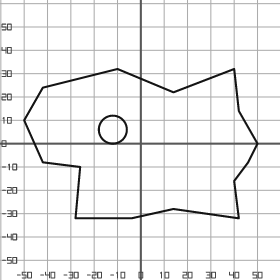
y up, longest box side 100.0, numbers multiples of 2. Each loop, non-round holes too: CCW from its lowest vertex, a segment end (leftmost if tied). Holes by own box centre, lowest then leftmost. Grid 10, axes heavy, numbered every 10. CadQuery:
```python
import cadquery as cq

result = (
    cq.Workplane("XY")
    .moveTo(-28.0, -32.0)
    .lineTo(-4.0, -32.0)
    .lineTo(14.0, -28.0)
    .lineTo(42.0, -32.0)
    .lineTo(40.0, -16.0)
    .lineTo(46.0, -8.0)
    .lineTo(50.0, 0.0)
    .lineTo(42.0, 14.0)
    .lineTo(40.0, 32.0)
    .lineTo(14.0, 22.0)
    .lineTo(-10.0, 32.0)
    .lineTo(-42.0, 24.0)
    .lineTo(-50.0, 10.0)
    .lineTo(-42.0, -8.0)
    .lineTo(-26.0, -10.0)
    .close()
    .moveTo(-12.0, 6.0)
    .circle(6.0)
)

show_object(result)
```